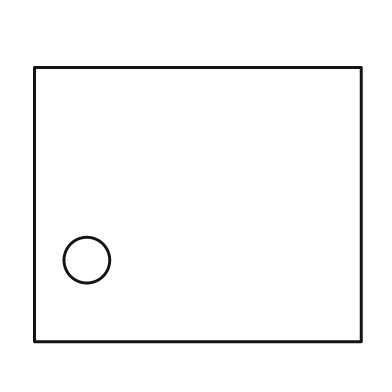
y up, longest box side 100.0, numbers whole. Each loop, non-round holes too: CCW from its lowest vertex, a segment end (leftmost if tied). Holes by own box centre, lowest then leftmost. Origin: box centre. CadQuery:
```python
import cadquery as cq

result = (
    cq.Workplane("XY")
    .moveTo(-50.0, -42.0)
    .lineTo(50.0, -42.0)
    .lineTo(50.0, 42.0)
    .lineTo(-50.0, 42.0)
    .close()
    .moveTo(-34.0, -17.0)
    .circle(7.0)
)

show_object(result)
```